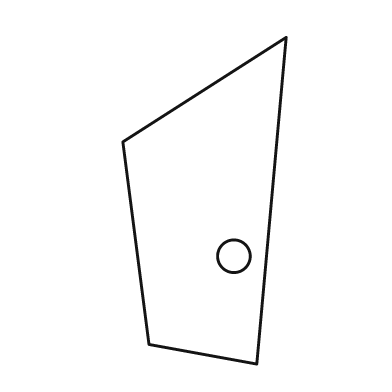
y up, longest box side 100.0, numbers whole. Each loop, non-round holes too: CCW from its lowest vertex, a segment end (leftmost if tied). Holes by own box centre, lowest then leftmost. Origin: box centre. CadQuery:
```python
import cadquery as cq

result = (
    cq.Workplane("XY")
    .moveTo(16.0, -50.0)
    .lineTo(25.0, 50.0)
    .lineTo(-25.0, 18.0)
    .lineTo(-17.0, -44.0)
    .close()
    .moveTo(9.0, -17.0)
    .circle(5.0)
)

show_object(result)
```